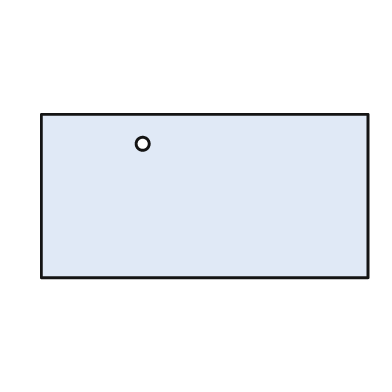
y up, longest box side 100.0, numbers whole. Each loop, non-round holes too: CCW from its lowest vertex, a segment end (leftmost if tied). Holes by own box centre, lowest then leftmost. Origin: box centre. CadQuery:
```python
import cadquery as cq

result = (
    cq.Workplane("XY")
    .moveTo(-50.0, -25.0)
    .lineTo(50.0, -25.0)
    .lineTo(50.0, 25.0)
    .lineTo(-50.0, 25.0)
    .close()
    .moveTo(-19.0, 16.0)
    .circle(2.0)
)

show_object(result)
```